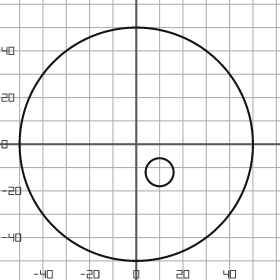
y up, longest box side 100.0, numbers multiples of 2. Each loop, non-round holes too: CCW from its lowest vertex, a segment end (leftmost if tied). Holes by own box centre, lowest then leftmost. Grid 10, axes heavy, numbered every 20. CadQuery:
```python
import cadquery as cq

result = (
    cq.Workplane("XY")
    .moveTo(0.0, 0.0)
    .circle(50.0)
    .moveTo(10.0, -12.0)
    .circle(6.0)
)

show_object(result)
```